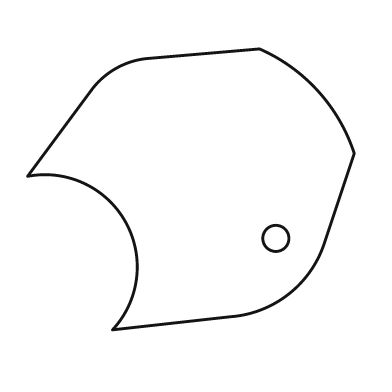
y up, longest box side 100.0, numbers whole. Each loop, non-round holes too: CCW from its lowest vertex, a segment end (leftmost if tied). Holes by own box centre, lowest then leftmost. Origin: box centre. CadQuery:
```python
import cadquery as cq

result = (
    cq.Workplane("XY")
    .moveTo(-24.0, -43.0)
    .lineTo(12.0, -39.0)
    .threePointArc((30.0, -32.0), (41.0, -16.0))
    .lineTo(50.0, 11.0)
    .threePointArc((39.0, 30.0), (21.0, 43.0))
    .lineTo(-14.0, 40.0)
    .threePointArc((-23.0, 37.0), (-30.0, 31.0))
    .lineTo(-50.0, 4.0)
    .threePointArc((-20.0, -10.0), (-24.0, -43.0))
    .close()
    .moveTo(26.0, -15.0)
    .circle(4.0)
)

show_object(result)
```